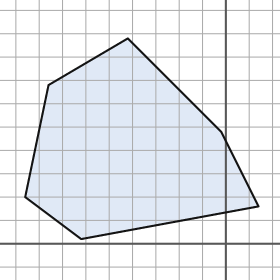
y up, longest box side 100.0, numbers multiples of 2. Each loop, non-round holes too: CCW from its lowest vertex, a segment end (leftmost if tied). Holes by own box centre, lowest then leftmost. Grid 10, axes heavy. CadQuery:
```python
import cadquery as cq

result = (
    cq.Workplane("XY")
    .moveTo(-62.0, 2.0)
    .lineTo(14.0, 16.0)
    .lineTo(-2.0, 48.0)
    .lineTo(-42.0, 88.0)
    .lineTo(-76.0, 68.0)
    .lineTo(-86.0, 20.0)
    .close()
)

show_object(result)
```